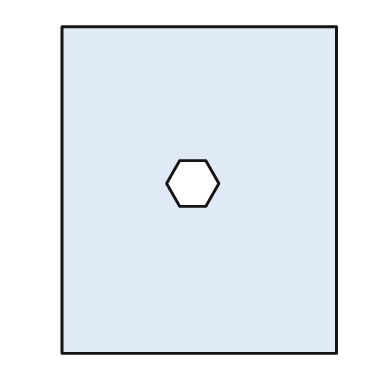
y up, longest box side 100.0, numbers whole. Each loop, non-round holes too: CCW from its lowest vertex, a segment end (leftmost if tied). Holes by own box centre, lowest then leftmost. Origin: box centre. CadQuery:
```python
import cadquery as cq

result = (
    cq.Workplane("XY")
    .moveTo(-42.0, -50.0)
    .lineTo(42.0, -50.0)
    .lineTo(42.0, 50.0)
    .lineTo(-42.0, 50.0)
    .close()
    .moveTo(-6.0, -5.0)
    .lineTo(2.0, -5.0)
    .lineTo(6.0, 2.0)
    .lineTo(2.0, 9.0)
    .lineTo(-6.0, 9.0)
    .lineTo(-10.0, 2.0)
    .close()
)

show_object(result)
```